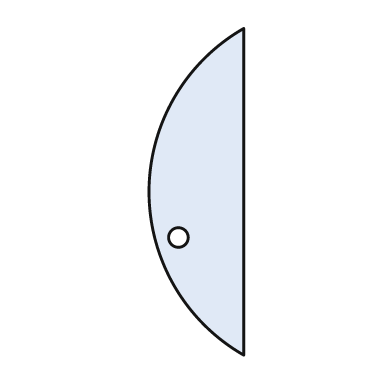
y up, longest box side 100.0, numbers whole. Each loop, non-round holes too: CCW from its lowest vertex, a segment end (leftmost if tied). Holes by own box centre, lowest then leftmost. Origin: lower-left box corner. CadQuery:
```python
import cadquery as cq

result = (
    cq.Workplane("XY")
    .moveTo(29.0, 0.0)
    .lineTo(29.0, 100.0)
    .threePointArc((0.0, 50.0), (29.0, 0.0))
    .close()
    .moveTo(9.0, 36.0)
    .circle(3.0)
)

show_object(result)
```